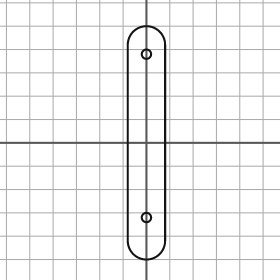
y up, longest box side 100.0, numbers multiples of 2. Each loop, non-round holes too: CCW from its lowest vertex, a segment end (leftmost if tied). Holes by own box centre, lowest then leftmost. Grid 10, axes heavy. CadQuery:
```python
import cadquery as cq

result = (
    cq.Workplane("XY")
    .moveTo(-8.0, -42.0)
    .threePointArc((0.0, -50.0), (8.0, -42.0))
    .lineTo(8.0, 42.0)
    .threePointArc((0.0, 50.0), (-8.0, 42.0))
    .close()
    .moveTo(0.0, -32.0)
    .circle(2.0)
    .moveTo(0.0, 38.0)
    .circle(2.0)
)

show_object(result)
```